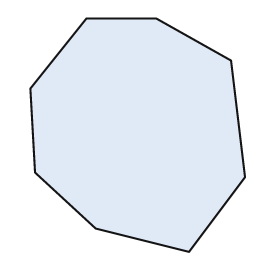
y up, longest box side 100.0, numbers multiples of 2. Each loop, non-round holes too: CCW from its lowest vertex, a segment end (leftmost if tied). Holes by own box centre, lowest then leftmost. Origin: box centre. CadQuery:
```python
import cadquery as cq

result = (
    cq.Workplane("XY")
    .moveTo(22.0, -50.0)
    .lineTo(46.0, -18.0)
    .lineTo(40.0, 32.0)
    .lineTo(8.0, 50.0)
    .lineTo(-22.0, 50.0)
    .lineTo(-46.0, 20.0)
    .lineTo(-44.0, -16.0)
    .lineTo(-18.0, -40.0)
    .close()
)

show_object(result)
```